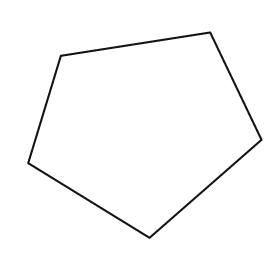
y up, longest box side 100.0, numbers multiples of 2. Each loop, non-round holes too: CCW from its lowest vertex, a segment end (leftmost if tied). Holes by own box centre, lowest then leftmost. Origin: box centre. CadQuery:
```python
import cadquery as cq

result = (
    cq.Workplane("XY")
    .moveTo(2.0, -44.0)
    .lineTo(50.0, -2.0)
    .lineTo(28.0, 44.0)
    .lineTo(-36.0, 34.0)
    .lineTo(-50.0, -12.0)
    .close()
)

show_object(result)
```